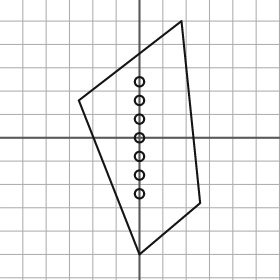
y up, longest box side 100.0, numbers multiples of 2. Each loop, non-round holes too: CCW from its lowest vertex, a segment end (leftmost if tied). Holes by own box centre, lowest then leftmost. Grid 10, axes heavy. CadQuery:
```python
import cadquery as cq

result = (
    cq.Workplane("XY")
    .moveTo(0.0, -50.0)
    .lineTo(26.0, -28.0)
    .lineTo(18.0, 50.0)
    .lineTo(-26.0, 16.0)
    .close()
    .moveTo(0.0, -24.0)
    .circle(2.0)
    .moveTo(0.0, -16.0)
    .circle(2.0)
    .moveTo(0.0, -8.0)
    .circle(2.0)
    .moveTo(0.0, 0.0)
    .circle(2.0)
    .moveTo(0.0, 8.0)
    .circle(2.0)
    .moveTo(0.0, 16.0)
    .circle(2.0)
    .moveTo(0.0, 24.0)
    .circle(2.0)
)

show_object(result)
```